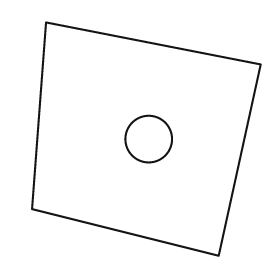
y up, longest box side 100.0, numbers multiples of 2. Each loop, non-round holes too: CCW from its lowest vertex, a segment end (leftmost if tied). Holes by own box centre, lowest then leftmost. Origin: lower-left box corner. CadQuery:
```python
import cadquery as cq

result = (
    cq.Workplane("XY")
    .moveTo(80.0, 0.0)
    .lineTo(98.0, 82.0)
    .lineTo(6.0, 100.0)
    .lineTo(0.0, 20.0)
    .close()
    .moveTo(50.0, 50.0)
    .circle(10.0)
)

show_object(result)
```